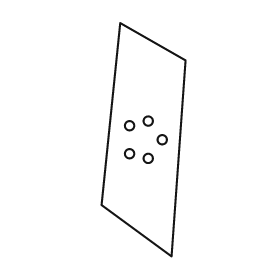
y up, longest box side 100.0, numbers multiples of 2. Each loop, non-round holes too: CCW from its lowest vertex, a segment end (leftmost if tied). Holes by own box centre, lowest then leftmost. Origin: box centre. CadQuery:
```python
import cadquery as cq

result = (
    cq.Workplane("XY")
    .moveTo(12.0, -50.0)
    .lineTo(18.0, 34.0)
    .lineTo(-10.0, 50.0)
    .lineTo(-18.0, -28.0)
    .close()
    .moveTo(2.0, -8.0)
    .circle(2.0)
    .moveTo(-6.0, -6.0)
    .circle(2.0)
    .moveTo(8.0, 0.0)
    .circle(2.0)
    .moveTo(-6.0, 6.0)
    .circle(2.0)
    .moveTo(2.0, 8.0)
    .circle(2.0)
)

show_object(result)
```